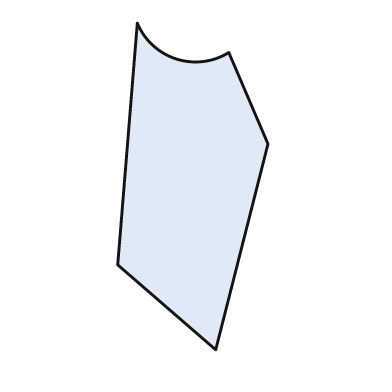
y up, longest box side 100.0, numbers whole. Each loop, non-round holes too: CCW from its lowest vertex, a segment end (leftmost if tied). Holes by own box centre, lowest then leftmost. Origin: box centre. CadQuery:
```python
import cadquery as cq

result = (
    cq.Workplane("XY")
    .moveTo(7.0, -50.0)
    .lineTo(23.0, 13.0)
    .lineTo(11.0, 41.0)
    .threePointArc((-5.0, 39.0), (-17.0, 50.0))
    .lineTo(-23.0, -24.0)
    .close()
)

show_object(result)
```